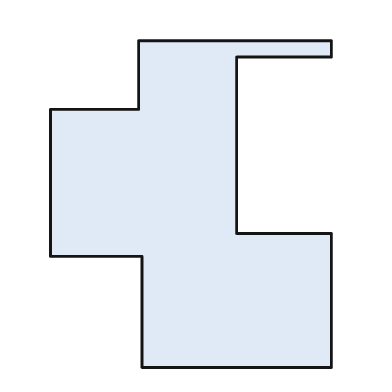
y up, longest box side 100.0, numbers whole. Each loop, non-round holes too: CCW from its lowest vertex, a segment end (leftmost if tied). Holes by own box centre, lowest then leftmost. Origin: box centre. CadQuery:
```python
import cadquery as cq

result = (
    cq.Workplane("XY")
    .moveTo(-15.0, -50.0)
    .lineTo(43.0, -50.0)
    .lineTo(43.0, -9.0)
    .lineTo(14.0, -9.0)
    .lineTo(14.0, 45.0)
    .lineTo(43.0, 45.0)
    .lineTo(43.0, 50.0)
    .lineTo(-16.0, 50.0)
    .lineTo(-16.0, 29.0)
    .lineTo(-43.0, 29.0)
    .lineTo(-43.0, -16.0)
    .lineTo(-15.0, -16.0)
    .close()
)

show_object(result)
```